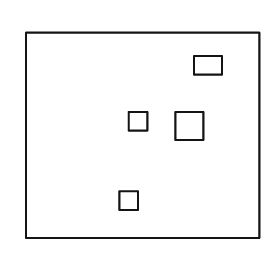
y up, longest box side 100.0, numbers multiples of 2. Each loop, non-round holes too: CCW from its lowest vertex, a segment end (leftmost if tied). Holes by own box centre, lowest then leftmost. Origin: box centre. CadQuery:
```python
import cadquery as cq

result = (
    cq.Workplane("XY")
    .moveTo(-50.0, -44.0)
    .lineTo(50.0, -44.0)
    .lineTo(50.0, 44.0)
    .lineTo(-50.0, 44.0)
    .close()
    .moveTo(-10.0, -32.0)
    .lineTo(-2.0, -32.0)
    .lineTo(-2.0, -24.0)
    .lineTo(-10.0, -24.0)
    .close()
    .moveTo(14.0, -2.0)
    .lineTo(26.0, -2.0)
    .lineTo(26.0, 10.0)
    .lineTo(14.0, 10.0)
    .close()
    .moveTo(-6.0, 2.0)
    .lineTo(2.0, 2.0)
    .lineTo(2.0, 10.0)
    .lineTo(-6.0, 10.0)
    .close()
    .moveTo(22.0, 26.0)
    .lineTo(34.0, 26.0)
    .lineTo(34.0, 34.0)
    .lineTo(22.0, 34.0)
    .close()
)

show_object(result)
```